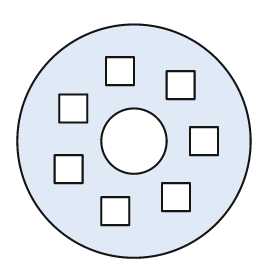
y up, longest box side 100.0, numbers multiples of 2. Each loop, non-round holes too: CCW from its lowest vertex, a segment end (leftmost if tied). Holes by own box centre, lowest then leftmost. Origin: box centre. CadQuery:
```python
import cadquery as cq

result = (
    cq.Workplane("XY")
    .moveTo(0.0, 0.0)
    .circle(50.0)
    .moveTo(-14.0, -36.0)
    .lineTo(-2.0, -36.0)
    .lineTo(-2.0, -24.0)
    .lineTo(-14.0, -24.0)
    .close()
    .moveTo(12.0, -30.0)
    .lineTo(24.0, -30.0)
    .lineTo(24.0, -18.0)
    .lineTo(12.0, -18.0)
    .close()
    .moveTo(-34.0, -18.0)
    .lineTo(-22.0, -18.0)
    .lineTo(-22.0, -6.0)
    .lineTo(-34.0, -6.0)
    .close()
    .moveTo(0.0, 0.0)
    .circle(14.0)
    .moveTo(24.0, -6.0)
    .lineTo(36.0, -6.0)
    .lineTo(36.0, 6.0)
    .lineTo(24.0, 6.0)
    .close()
    .moveTo(-32.0, 8.0)
    .lineTo(-20.0, 8.0)
    .lineTo(-20.0, 20.0)
    .lineTo(-32.0, 20.0)
    .close()
    .moveTo(14.0, 18.0)
    .lineTo(26.0, 18.0)
    .lineTo(26.0, 30.0)
    .lineTo(14.0, 30.0)
    .close()
    .moveTo(-12.0, 24.0)
    .lineTo(0.0, 24.0)
    .lineTo(0.0, 36.0)
    .lineTo(-12.0, 36.0)
    .close()
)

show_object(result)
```